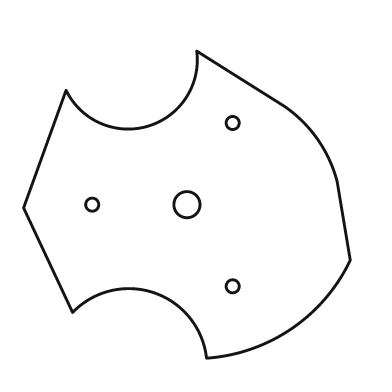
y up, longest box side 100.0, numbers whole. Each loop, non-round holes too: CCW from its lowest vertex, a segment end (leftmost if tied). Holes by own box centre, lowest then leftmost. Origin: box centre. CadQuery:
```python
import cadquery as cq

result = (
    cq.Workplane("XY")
    .moveTo(6.0, -47.0)
    .threePointArc((32.0, -38.0), (50.0, -17.0))
    .lineTo(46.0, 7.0)
    .threePointArc((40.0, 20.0), (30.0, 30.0))
    .lineTo(3.0, 47.0)
    .threePointArc((-12.0, 24.0), (-37.0, 35.0))
    .lineTo(-50.0, -1.0)
    .lineTo(-35.0, -33.0)
    .threePointArc((-10.0, -27.0), (6.0, -47.0))
    .close()
    .moveTo(14.0, -25.0)
    .circle(2.0)
    .moveTo(-29.0, 0.0)
    .circle(2.0)
    .moveTo(0.0, 0.0)
    .circle(4.0)
    .moveTo(14.0, 25.0)
    .circle(2.0)
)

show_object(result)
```